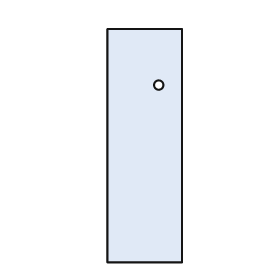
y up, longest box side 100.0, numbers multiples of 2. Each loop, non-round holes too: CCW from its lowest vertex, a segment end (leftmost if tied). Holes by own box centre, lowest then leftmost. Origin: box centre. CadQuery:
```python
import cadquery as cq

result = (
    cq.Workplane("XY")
    .moveTo(-16.0, -50.0)
    .lineTo(16.0, -50.0)
    .lineTo(16.0, 50.0)
    .lineTo(-16.0, 50.0)
    .close()
    .moveTo(6.0, 26.0)
    .circle(2.0)
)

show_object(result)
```